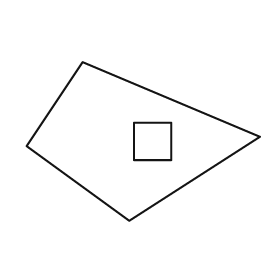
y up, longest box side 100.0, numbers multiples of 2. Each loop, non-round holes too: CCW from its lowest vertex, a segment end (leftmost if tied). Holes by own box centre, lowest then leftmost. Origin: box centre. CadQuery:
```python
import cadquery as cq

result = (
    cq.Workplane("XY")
    .moveTo(-6.0, -34.0)
    .lineTo(50.0, 2.0)
    .lineTo(-26.0, 34.0)
    .lineTo(-50.0, -2.0)
    .close()
    .moveTo(-4.0, -8.0)
    .lineTo(12.0, -8.0)
    .lineTo(12.0, 8.0)
    .lineTo(-4.0, 8.0)
    .close()
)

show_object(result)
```